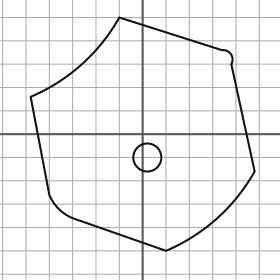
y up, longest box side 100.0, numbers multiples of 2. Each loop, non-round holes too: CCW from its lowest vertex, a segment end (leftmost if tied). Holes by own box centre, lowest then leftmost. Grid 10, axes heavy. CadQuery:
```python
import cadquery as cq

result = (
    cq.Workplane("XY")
    .moveTo(10.0, -50.0)
    .threePointArc((32.0, -36.0), (48.0, -16.0))
    .lineTo(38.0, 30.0)
    .threePointArc((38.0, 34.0), (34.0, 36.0))
    .lineTo(-10.0, 50.0)
    .threePointArc((-26.0, 30.0), (-48.0, 16.0))
    .lineTo(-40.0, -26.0)
    .threePointArc((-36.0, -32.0), (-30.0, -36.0))
    .close()
    .moveTo(2.0, -10.0)
    .circle(6.0)
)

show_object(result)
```